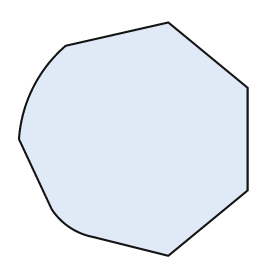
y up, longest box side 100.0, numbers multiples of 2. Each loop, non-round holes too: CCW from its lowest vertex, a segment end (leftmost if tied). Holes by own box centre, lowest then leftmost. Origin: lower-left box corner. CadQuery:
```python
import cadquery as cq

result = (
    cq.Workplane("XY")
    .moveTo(64.0, 0.0)
    .lineTo(98.0, 28.0)
    .lineTo(98.0, 72.0)
    .lineTo(64.0, 100.0)
    .lineTo(20.0, 90.0)
    .threePointArc((6.0, 72.0), (0.0, 50.0))
    .lineTo(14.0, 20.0)
    .threePointArc((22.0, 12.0), (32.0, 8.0))
    .close()
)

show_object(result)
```